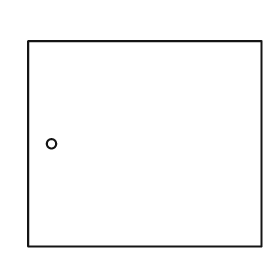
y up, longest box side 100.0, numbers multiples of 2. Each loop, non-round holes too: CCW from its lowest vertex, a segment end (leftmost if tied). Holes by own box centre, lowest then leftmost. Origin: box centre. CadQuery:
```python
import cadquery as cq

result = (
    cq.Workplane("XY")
    .moveTo(-50.0, -44.0)
    .lineTo(50.0, -44.0)
    .lineTo(50.0, 44.0)
    .lineTo(-50.0, 44.0)
    .close()
    .moveTo(-40.0, 0.0)
    .circle(2.0)
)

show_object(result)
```